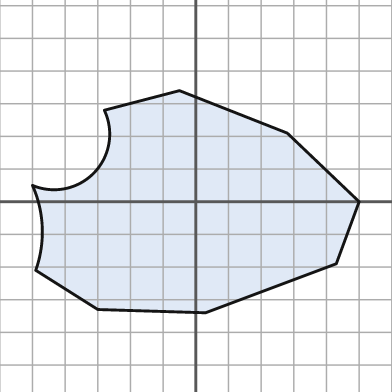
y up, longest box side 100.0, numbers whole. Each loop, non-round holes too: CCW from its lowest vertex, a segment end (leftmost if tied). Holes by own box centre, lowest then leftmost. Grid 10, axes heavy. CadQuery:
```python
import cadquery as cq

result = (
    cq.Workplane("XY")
    .moveTo(3.0, -34.0)
    .lineTo(43.0, -19.0)
    .lineTo(50.0, 0.0)
    .lineTo(28.0, 21.0)
    .lineTo(-5.0, 34.0)
    .lineTo(-28.0, 28.0)
    .threePointArc((-31.0, 9.0), (-50.0, 5.0))
    .threePointArc((-47.0, -8.0), (-49.0, -21.0))
    .lineTo(-30.0, -33.0)
    .close()
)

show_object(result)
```